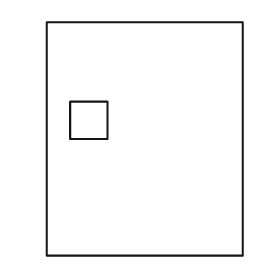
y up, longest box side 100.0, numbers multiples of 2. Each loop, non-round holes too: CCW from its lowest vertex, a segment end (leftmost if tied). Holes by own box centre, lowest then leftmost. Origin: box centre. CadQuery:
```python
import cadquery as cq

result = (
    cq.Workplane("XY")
    .moveTo(-42.0, -50.0)
    .lineTo(42.0, -50.0)
    .lineTo(42.0, 50.0)
    .lineTo(-42.0, 50.0)
    .close()
    .moveTo(-32.0, 0.0)
    .lineTo(-16.0, 0.0)
    .lineTo(-16.0, 16.0)
    .lineTo(-32.0, 16.0)
    .close()
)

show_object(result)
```